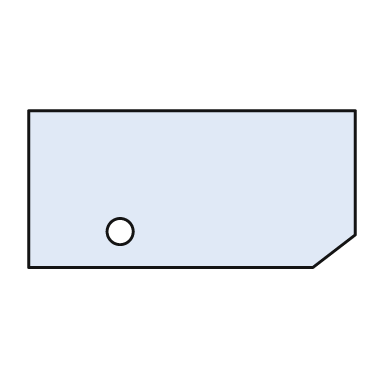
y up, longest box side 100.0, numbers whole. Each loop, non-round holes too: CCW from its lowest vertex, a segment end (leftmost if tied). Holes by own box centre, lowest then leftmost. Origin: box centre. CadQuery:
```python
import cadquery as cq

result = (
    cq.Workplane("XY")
    .moveTo(-50.0, -24.0)
    .lineTo(37.0, -24.0)
    .lineTo(50.0, -14.0)
    .lineTo(50.0, 24.0)
    .lineTo(-50.0, 24.0)
    .close()
    .moveTo(-22.0, -13.0)
    .circle(4.0)
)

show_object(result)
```